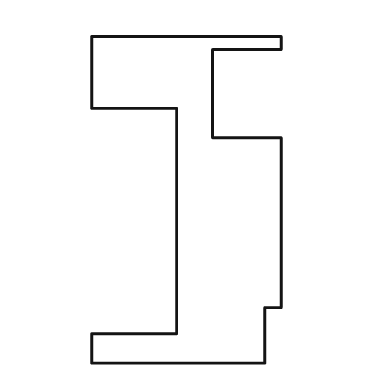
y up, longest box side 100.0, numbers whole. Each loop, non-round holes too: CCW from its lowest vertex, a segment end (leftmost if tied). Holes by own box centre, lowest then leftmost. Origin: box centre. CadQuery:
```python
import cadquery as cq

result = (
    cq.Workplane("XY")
    .moveTo(-29.0, -50.0)
    .lineTo(24.0, -50.0)
    .lineTo(24.0, -33.0)
    .lineTo(29.0, -33.0)
    .lineTo(29.0, 19.0)
    .lineTo(8.0, 19.0)
    .lineTo(8.0, 46.0)
    .lineTo(29.0, 46.0)
    .lineTo(29.0, 50.0)
    .lineTo(-29.0, 50.0)
    .lineTo(-29.0, 28.0)
    .lineTo(-3.0, 28.0)
    .lineTo(-3.0, -41.0)
    .lineTo(-29.0, -41.0)
    .close()
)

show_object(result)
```